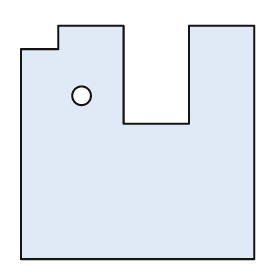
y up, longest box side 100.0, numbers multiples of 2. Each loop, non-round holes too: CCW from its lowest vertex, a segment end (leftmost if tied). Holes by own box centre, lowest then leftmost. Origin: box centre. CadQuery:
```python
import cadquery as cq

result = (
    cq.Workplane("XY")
    .moveTo(-50.0, -50.0)
    .lineTo(50.0, -50.0)
    .lineTo(50.0, 50.0)
    .lineTo(22.0, 50.0)
    .lineTo(22.0, 8.0)
    .lineTo(-6.0, 8.0)
    .lineTo(-6.0, 50.0)
    .lineTo(-34.0, 50.0)
    .lineTo(-34.0, 40.0)
    .lineTo(-50.0, 40.0)
    .close()
    .moveTo(-24.0, 20.0)
    .circle(4.0)
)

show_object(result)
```